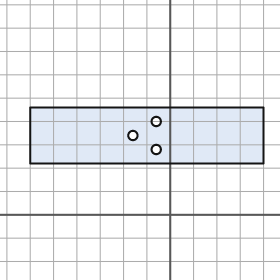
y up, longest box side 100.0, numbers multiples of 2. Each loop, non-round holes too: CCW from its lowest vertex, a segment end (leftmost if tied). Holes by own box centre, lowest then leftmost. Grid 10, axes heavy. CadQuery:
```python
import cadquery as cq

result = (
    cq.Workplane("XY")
    .moveTo(-60.0, 22.0)
    .lineTo(40.0, 22.0)
    .lineTo(40.0, 46.0)
    .lineTo(-60.0, 46.0)
    .close()
    .moveTo(-6.0, 28.0)
    .circle(2.0)
    .moveTo(-16.0, 34.0)
    .circle(2.0)
    .moveTo(-6.0, 40.0)
    .circle(2.0)
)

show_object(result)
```